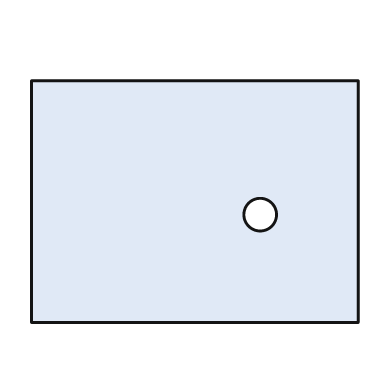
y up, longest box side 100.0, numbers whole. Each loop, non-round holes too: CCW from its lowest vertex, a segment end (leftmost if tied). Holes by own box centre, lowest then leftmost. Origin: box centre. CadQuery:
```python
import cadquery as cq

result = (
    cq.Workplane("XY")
    .moveTo(-50.0, -37.0)
    .lineTo(50.0, -37.0)
    .lineTo(50.0, 37.0)
    .lineTo(-50.0, 37.0)
    .close()
    .moveTo(20.0, -4.0)
    .circle(5.0)
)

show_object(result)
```